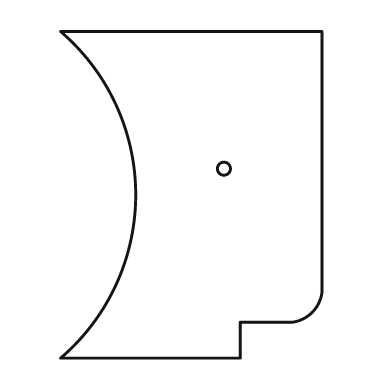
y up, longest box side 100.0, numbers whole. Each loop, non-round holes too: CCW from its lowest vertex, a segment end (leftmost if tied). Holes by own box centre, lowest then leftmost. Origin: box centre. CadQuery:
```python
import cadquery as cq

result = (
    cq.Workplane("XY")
    .moveTo(-40.0, -50.0)
    .lineTo(15.0, -50.0)
    .lineTo(15.0, -39.0)
    .lineTo(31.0, -39.0)
    .threePointArc((37.0, -36.0), (40.0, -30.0))
    .lineTo(40.0, 50.0)
    .lineTo(-40.0, 50.0)
    .threePointArc((-17.0, 0.0), (-40.0, -50.0))
    .close()
    .moveTo(10.0, 8.0)
    .circle(2.0)
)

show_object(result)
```